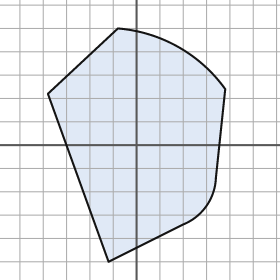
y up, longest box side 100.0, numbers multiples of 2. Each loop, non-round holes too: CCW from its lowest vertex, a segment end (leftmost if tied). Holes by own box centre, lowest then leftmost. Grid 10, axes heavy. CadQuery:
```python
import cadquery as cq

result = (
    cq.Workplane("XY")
    .moveTo(-12.0, -50.0)
    .lineTo(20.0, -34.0)
    .threePointArc((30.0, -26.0), (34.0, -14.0))
    .lineTo(38.0, 24.0)
    .threePointArc((18.0, 42.0), (-8.0, 50.0))
    .lineTo(-38.0, 22.0)
    .close()
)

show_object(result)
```